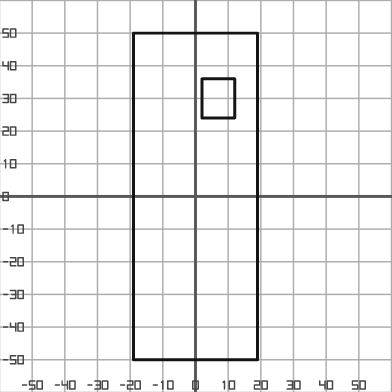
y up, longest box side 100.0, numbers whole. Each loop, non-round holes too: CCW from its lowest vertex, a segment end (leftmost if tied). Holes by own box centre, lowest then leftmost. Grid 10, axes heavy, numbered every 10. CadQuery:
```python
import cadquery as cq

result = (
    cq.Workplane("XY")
    .moveTo(-19.0, -50.0)
    .lineTo(19.0, -50.0)
    .lineTo(19.0, 50.0)
    .lineTo(-19.0, 50.0)
    .close()
    .moveTo(2.0, 24.0)
    .lineTo(12.0, 24.0)
    .lineTo(12.0, 36.0)
    .lineTo(2.0, 36.0)
    .close()
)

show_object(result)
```